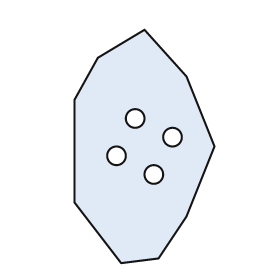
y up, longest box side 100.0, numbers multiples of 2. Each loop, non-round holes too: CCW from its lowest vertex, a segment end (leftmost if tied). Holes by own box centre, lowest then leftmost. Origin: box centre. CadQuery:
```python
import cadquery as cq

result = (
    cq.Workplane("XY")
    .moveTo(-10.0, -50.0)
    .lineTo(6.0, -48.0)
    .lineTo(18.0, -30.0)
    .lineTo(30.0, 0.0)
    .lineTo(18.0, 30.0)
    .lineTo(0.0, 50.0)
    .lineTo(-20.0, 38.0)
    .lineTo(-30.0, 20.0)
    .lineTo(-30.0, -24.0)
    .close()
    .moveTo(4.0, -12.0)
    .circle(4.0)
    .moveTo(-12.0, -4.0)
    .circle(4.0)
    .moveTo(12.0, 4.0)
    .circle(4.0)
    .moveTo(-4.0, 12.0)
    .circle(4.0)
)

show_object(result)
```